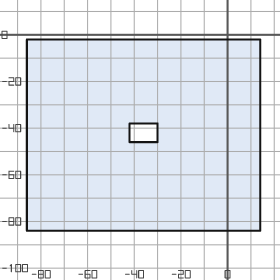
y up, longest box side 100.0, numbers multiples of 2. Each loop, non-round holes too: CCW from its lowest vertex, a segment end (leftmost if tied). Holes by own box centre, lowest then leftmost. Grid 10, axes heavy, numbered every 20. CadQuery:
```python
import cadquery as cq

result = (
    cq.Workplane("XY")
    .moveTo(-86.0, -84.0)
    .lineTo(14.0, -84.0)
    .lineTo(14.0, -2.0)
    .lineTo(-86.0, -2.0)
    .close()
    .moveTo(-42.0, -46.0)
    .lineTo(-30.0, -46.0)
    .lineTo(-30.0, -38.0)
    .lineTo(-42.0, -38.0)
    .close()
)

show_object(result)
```